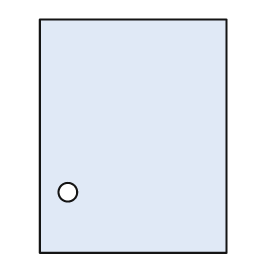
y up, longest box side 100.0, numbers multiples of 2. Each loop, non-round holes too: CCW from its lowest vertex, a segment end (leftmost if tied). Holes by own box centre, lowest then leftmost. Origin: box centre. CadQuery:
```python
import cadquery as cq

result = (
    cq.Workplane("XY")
    .moveTo(-40.0, -50.0)
    .lineTo(40.0, -50.0)
    .lineTo(40.0, 50.0)
    .lineTo(-40.0, 50.0)
    .close()
    .moveTo(-28.0, -24.0)
    .circle(4.0)
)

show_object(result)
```